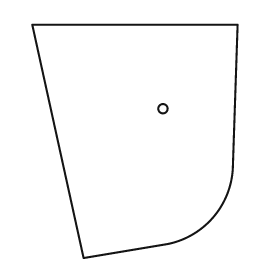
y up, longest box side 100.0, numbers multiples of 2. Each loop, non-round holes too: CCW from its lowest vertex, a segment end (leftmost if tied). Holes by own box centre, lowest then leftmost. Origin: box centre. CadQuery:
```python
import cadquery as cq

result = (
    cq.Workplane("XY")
    .moveTo(-22.0, -50.0)
    .lineTo(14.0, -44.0)
    .threePointArc((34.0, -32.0), (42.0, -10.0))
    .lineTo(44.0, 50.0)
    .lineTo(-44.0, 50.0)
    .close()
    .moveTo(12.0, 14.0)
    .circle(2.0)
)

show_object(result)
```